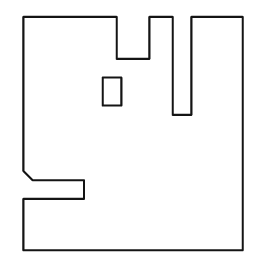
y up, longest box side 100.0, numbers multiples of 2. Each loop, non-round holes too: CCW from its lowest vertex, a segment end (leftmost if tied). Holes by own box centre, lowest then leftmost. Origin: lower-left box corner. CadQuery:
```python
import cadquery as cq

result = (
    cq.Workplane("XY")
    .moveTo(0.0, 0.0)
    .lineTo(94.0, 0.0)
    .lineTo(94.0, 100.0)
    .lineTo(72.0, 100.0)
    .lineTo(72.0, 58.0)
    .lineTo(64.0, 58.0)
    .lineTo(64.0, 100.0)
    .lineTo(54.0, 100.0)
    .lineTo(54.0, 82.0)
    .lineTo(40.0, 82.0)
    .lineTo(40.0, 100.0)
    .lineTo(0.0, 100.0)
    .lineTo(0.0, 34.0)
    .lineTo(4.0, 30.0)
    .lineTo(26.0, 30.0)
    .lineTo(26.0, 22.0)
    .lineTo(0.0, 22.0)
    .close()
    .moveTo(34.0, 62.0)
    .lineTo(42.0, 62.0)
    .lineTo(42.0, 74.0)
    .lineTo(34.0, 74.0)
    .close()
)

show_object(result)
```